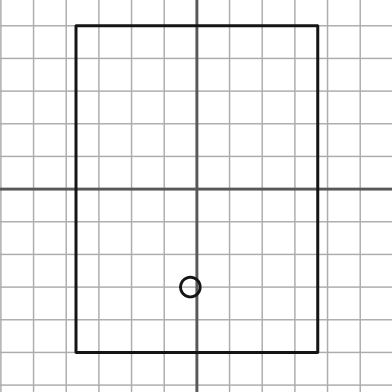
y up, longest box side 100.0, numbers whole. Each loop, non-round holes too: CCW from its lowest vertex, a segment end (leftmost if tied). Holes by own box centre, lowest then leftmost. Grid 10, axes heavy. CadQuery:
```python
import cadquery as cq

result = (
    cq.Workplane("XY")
    .moveTo(-37.0, -50.0)
    .lineTo(37.0, -50.0)
    .lineTo(37.0, 50.0)
    .lineTo(-37.0, 50.0)
    .close()
    .moveTo(-2.0, -30.0)
    .circle(3.0)
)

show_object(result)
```